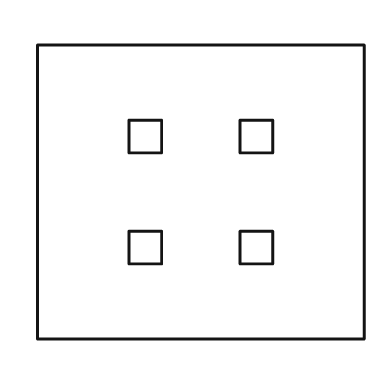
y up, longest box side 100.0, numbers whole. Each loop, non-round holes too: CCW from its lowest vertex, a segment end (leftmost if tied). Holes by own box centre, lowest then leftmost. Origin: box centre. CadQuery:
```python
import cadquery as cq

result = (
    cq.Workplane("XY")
    .moveTo(-50.0, -45.0)
    .lineTo(50.0, -45.0)
    .lineTo(50.0, 45.0)
    .lineTo(-50.0, 45.0)
    .close()
    .moveTo(-22.0, -22.0)
    .lineTo(-12.0, -22.0)
    .lineTo(-12.0, -12.0)
    .lineTo(-22.0, -12.0)
    .close()
    .moveTo(12.0, -22.0)
    .lineTo(22.0, -22.0)
    .lineTo(22.0, -12.0)
    .lineTo(12.0, -12.0)
    .close()
    .moveTo(-22.0, 12.0)
    .lineTo(-12.0, 12.0)
    .lineTo(-12.0, 22.0)
    .lineTo(-22.0, 22.0)
    .close()
    .moveTo(12.0, 12.0)
    .lineTo(22.0, 12.0)
    .lineTo(22.0, 22.0)
    .lineTo(12.0, 22.0)
    .close()
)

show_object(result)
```